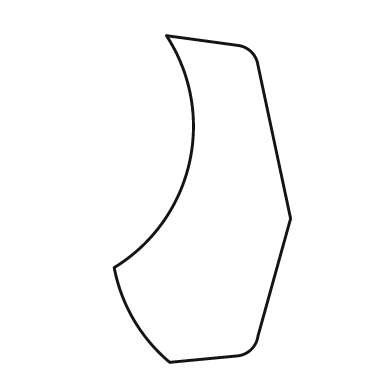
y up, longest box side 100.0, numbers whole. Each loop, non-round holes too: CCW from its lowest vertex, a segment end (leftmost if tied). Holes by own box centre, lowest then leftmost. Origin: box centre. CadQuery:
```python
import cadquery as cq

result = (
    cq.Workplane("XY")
    .moveTo(-10.0, -50.0)
    .lineTo(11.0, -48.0)
    .threePointArc((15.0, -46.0), (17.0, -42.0))
    .lineTo(27.0, -6.0)
    .lineTo(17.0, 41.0)
    .threePointArc((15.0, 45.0), (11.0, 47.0))
    .lineTo(-11.0, 50.0)
    .threePointArc((-4.0, 11.0), (-27.0, -21.0))
    .threePointArc((-21.0, -37.0), (-10.0, -50.0))
    .close()
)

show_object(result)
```